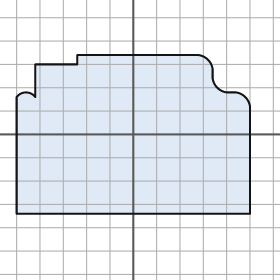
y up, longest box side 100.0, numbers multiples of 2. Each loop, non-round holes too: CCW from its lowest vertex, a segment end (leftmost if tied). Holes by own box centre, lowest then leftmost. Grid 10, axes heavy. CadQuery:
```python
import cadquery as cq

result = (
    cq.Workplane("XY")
    .moveTo(-50.0, -34.0)
    .lineTo(50.0, -34.0)
    .lineTo(50.0, 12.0)
    .threePointArc((48.0, 16.0), (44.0, 18.0))
    .lineTo(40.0, 18.0)
    .threePointArc((36.0, 20.0), (34.0, 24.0))
    .lineTo(34.0, 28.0)
    .threePointArc((32.0, 32.0), (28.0, 34.0))
    .lineTo(-24.0, 34.0)
    .lineTo(-24.0, 30.0)
    .lineTo(-42.0, 30.0)
    .lineTo(-42.0, 16.0)
    .threePointArc((-46.0, 18.0), (-50.0, 16.0))
    .close()
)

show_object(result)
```